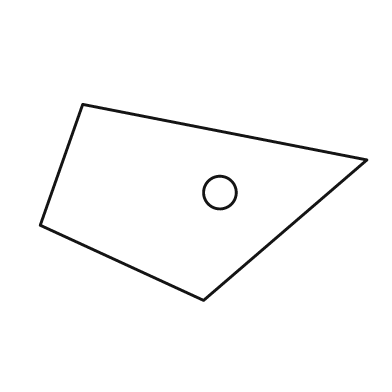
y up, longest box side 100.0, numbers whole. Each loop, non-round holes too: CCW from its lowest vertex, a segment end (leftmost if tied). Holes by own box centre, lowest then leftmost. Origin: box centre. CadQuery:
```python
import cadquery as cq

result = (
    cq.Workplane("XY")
    .moveTo(0.0, -30.0)
    .lineTo(50.0, 13.0)
    .lineTo(-37.0, 30.0)
    .lineTo(-50.0, -7.0)
    .close()
    .moveTo(5.0, 3.0)
    .circle(5.0)
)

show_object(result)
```